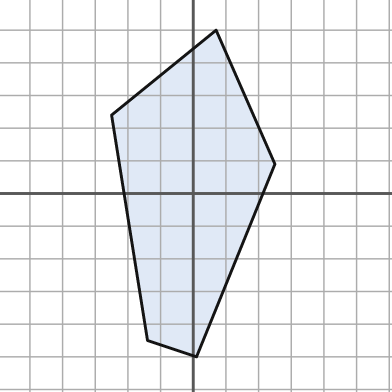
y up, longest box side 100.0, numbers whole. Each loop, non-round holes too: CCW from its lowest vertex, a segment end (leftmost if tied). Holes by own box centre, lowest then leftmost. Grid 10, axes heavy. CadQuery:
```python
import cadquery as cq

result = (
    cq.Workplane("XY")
    .moveTo(1.0, -50.0)
    .lineTo(25.0, 9.0)
    .lineTo(7.0, 50.0)
    .lineTo(-25.0, 24.0)
    .lineTo(-14.0, -45.0)
    .close()
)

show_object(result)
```